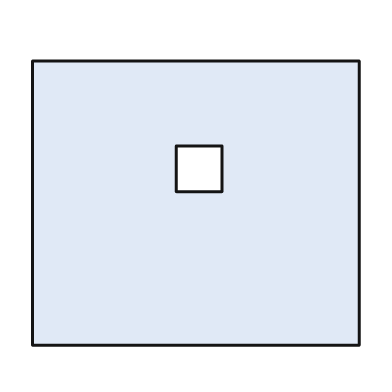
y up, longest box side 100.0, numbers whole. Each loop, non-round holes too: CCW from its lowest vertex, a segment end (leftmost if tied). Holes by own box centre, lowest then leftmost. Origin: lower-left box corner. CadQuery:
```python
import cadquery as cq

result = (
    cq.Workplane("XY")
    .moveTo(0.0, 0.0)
    .lineTo(100.0, 0.0)
    .lineTo(100.0, 87.0)
    .lineTo(0.0, 87.0)
    .close()
    .moveTo(44.0, 47.0)
    .lineTo(58.0, 47.0)
    .lineTo(58.0, 61.0)
    .lineTo(44.0, 61.0)
    .close()
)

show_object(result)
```